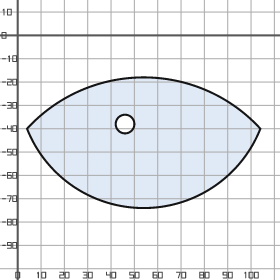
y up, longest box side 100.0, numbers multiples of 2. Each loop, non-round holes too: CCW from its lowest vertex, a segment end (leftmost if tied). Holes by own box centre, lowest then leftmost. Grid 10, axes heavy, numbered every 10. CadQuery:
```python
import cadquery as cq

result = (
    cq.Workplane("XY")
    .moveTo(4.0, -40.0)
    .threePointArc((54.0, -74.0), (104.0, -40.0))
    .threePointArc((54.0, -18.0), (4.0, -40.0))
    .close()
    .moveTo(46.0, -38.0)
    .circle(4.0)
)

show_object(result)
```